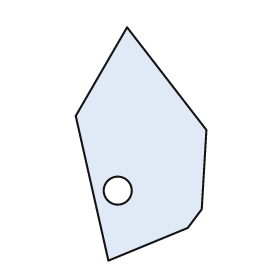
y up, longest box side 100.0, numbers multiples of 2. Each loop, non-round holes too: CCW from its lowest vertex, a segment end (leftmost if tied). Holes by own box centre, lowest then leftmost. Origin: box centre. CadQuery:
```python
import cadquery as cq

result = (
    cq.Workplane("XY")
    .moveTo(-14.0, -50.0)
    .lineTo(20.0, -36.0)
    .lineTo(26.0, -28.0)
    .lineTo(28.0, 6.0)
    .lineTo(-6.0, 50.0)
    .lineTo(-28.0, 12.0)
    .close()
    .moveTo(-10.0, -20.0)
    .circle(6.0)
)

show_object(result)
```